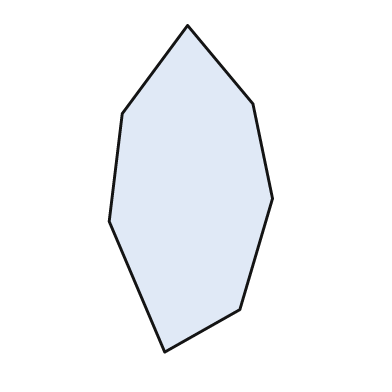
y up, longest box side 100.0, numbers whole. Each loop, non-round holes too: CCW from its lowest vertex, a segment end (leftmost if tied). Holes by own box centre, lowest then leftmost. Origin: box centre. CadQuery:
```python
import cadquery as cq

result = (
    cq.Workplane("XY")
    .moveTo(-8.0, -50.0)
    .lineTo(15.0, -37.0)
    .lineTo(25.0, -3.0)
    .lineTo(19.0, 26.0)
    .lineTo(-1.0, 50.0)
    .lineTo(-21.0, 23.0)
    .lineTo(-25.0, -10.0)
    .close()
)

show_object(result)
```